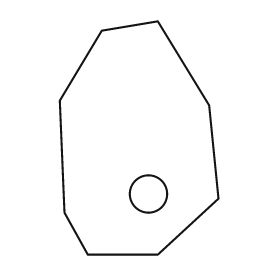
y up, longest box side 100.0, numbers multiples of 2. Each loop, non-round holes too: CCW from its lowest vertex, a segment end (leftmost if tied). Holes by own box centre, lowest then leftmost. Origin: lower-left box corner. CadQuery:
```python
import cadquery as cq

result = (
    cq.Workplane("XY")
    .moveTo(12.0, 0.0)
    .lineTo(42.0, 0.0)
    .lineTo(68.0, 24.0)
    .lineTo(64.0, 64.0)
    .lineTo(42.0, 100.0)
    .lineTo(18.0, 96.0)
    .lineTo(0.0, 66.0)
    .lineTo(2.0, 18.0)
    .close()
    .moveTo(38.0, 26.0)
    .circle(8.0)
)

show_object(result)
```